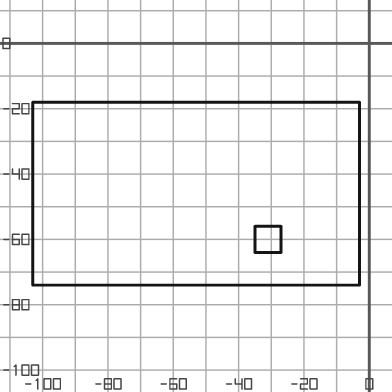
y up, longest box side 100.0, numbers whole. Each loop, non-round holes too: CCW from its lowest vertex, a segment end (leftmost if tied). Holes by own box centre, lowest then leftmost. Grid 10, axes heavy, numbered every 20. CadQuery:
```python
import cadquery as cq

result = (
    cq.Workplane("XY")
    .moveTo(-103.0, -74.0)
    .lineTo(-3.0, -74.0)
    .lineTo(-3.0, -18.0)
    .lineTo(-103.0, -18.0)
    .close()
    .moveTo(-35.0, -64.0)
    .lineTo(-27.0, -64.0)
    .lineTo(-27.0, -56.0)
    .lineTo(-35.0, -56.0)
    .close()
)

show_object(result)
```